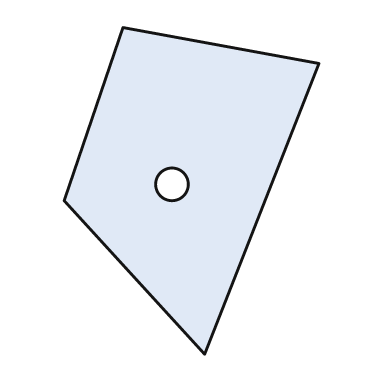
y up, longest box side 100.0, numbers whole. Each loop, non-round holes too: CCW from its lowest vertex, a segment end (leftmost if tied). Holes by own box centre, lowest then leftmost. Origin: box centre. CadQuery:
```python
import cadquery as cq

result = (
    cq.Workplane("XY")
    .moveTo(4.0, -50.0)
    .lineTo(39.0, 39.0)
    .lineTo(-21.0, 50.0)
    .lineTo(-39.0, -3.0)
    .close()
    .moveTo(-6.0, 2.0)
    .circle(5.0)
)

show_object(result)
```